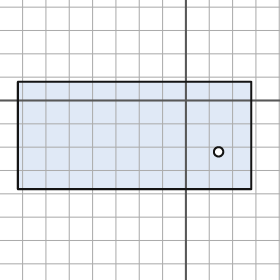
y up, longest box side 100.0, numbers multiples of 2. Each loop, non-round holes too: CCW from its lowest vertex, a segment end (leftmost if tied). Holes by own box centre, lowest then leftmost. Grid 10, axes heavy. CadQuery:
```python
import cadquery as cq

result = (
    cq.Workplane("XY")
    .moveTo(-72.0, -38.0)
    .lineTo(28.0, -38.0)
    .lineTo(28.0, 8.0)
    .lineTo(-72.0, 8.0)
    .close()
    .moveTo(14.0, -22.0)
    .circle(2.0)
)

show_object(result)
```